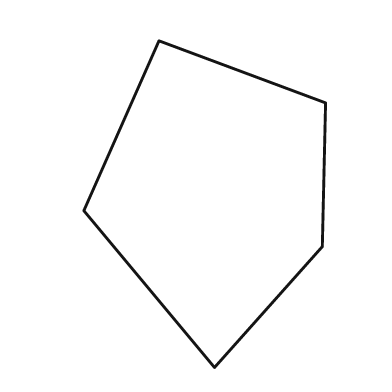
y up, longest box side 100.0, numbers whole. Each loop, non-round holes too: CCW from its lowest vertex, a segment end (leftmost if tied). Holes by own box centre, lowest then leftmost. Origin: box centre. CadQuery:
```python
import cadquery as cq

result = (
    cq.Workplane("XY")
    .moveTo(3.0, -50.0)
    .lineTo(36.0, -13.0)
    .lineTo(37.0, 31.0)
    .lineTo(-14.0, 50.0)
    .lineTo(-37.0, -2.0)
    .close()
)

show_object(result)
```